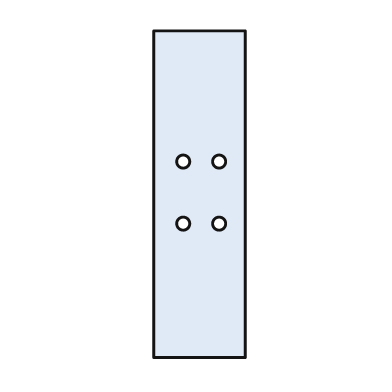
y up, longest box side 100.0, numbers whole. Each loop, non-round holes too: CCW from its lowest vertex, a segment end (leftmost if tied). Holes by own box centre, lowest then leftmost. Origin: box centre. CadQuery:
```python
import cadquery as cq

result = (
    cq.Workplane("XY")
    .moveTo(-14.0, -50.0)
    .lineTo(14.0, -50.0)
    .lineTo(14.0, 50.0)
    .lineTo(-14.0, 50.0)
    .close()
    .moveTo(-5.0, -9.0)
    .circle(2.0)
    .moveTo(6.0, -9.0)
    .circle(2.0)
    .moveTo(-5.0, 10.0)
    .circle(2.0)
    .moveTo(6.0, 10.0)
    .circle(2.0)
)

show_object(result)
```